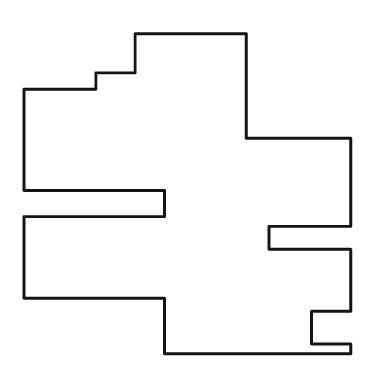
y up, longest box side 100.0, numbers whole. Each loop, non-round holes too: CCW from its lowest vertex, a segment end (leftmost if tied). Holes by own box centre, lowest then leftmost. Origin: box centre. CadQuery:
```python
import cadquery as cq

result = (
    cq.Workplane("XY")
    .moveTo(-7.0, -49.0)
    .lineTo(50.0, -49.0)
    .lineTo(50.0, -46.0)
    .lineTo(38.0, -46.0)
    .lineTo(38.0, -36.0)
    .lineTo(50.0, -36.0)
    .lineTo(50.0, -17.0)
    .lineTo(25.0, -17.0)
    .lineTo(25.0, -10.0)
    .lineTo(50.0, -10.0)
    .lineTo(50.0, 17.0)
    .lineTo(18.0, 17.0)
    .lineTo(18.0, 49.0)
    .lineTo(-16.0, 49.0)
    .lineTo(-16.0, 37.0)
    .lineTo(-28.0, 37.0)
    .lineTo(-28.0, 32.0)
    .lineTo(-50.0, 32.0)
    .lineTo(-50.0, 1.0)
    .lineTo(-7.0, 1.0)
    .lineTo(-7.0, -7.0)
    .lineTo(-50.0, -7.0)
    .lineTo(-50.0, -32.0)
    .lineTo(-7.0, -32.0)
    .close()
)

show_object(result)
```